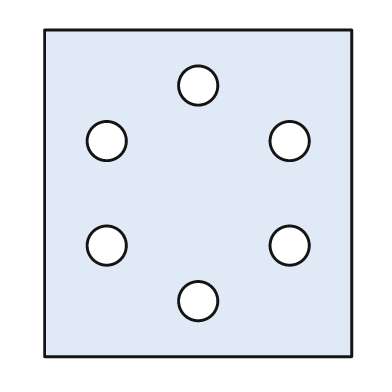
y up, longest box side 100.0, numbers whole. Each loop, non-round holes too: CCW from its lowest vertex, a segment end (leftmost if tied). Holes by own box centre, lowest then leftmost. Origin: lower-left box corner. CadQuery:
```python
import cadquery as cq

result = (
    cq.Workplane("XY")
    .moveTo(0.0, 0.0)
    .lineTo(94.0, 0.0)
    .lineTo(94.0, 100.0)
    .lineTo(0.0, 100.0)
    .close()
    .moveTo(47.0, 17.0)
    .circle(6.0)
    .moveTo(19.0, 34.0)
    .circle(6.0)
    .moveTo(75.0, 34.0)
    .circle(6.0)
    .moveTo(19.0, 66.0)
    .circle(6.0)
    .moveTo(75.0, 66.0)
    .circle(6.0)
    .moveTo(47.0, 83.0)
    .circle(6.0)
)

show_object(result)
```